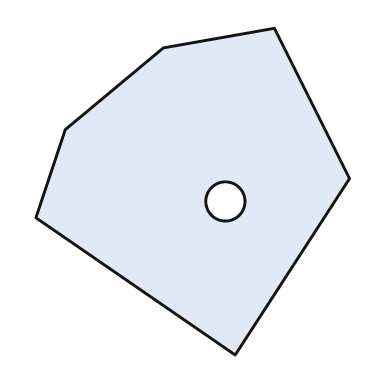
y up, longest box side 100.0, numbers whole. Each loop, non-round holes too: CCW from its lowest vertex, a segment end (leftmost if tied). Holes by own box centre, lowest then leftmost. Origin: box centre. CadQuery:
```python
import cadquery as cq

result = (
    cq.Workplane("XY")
    .moveTo(13.0, -50.0)
    .lineTo(48.0, 4.0)
    .lineTo(25.0, 50.0)
    .lineTo(-9.0, 44.0)
    .lineTo(-39.0, 19.0)
    .lineTo(-48.0, -8.0)
    .close()
    .moveTo(10.0, -3.0)
    .circle(6.0)
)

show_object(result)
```